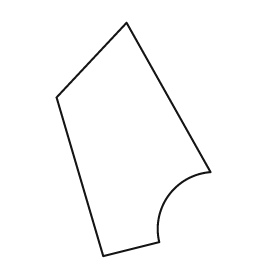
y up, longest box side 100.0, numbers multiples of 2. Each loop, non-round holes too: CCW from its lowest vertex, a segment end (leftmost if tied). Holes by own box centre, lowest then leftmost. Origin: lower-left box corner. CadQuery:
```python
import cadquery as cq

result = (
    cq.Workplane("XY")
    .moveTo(20.0, 0.0)
    .lineTo(44.0, 6.0)
    .threePointArc((48.0, 26.0), (66.0, 36.0))
    .lineTo(30.0, 100.0)
    .lineTo(0.0, 68.0)
    .close()
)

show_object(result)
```